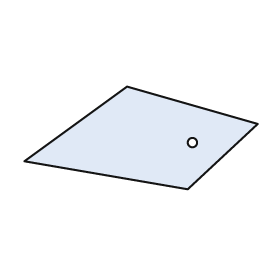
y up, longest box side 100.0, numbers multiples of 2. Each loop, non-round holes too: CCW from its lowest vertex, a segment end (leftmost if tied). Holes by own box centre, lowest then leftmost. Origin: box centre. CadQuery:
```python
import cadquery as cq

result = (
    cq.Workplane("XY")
    .moveTo(20.0, -22.0)
    .lineTo(50.0, 6.0)
    .lineTo(-6.0, 22.0)
    .lineTo(-50.0, -10.0)
    .close()
    .moveTo(22.0, -2.0)
    .circle(2.0)
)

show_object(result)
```